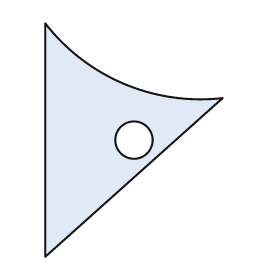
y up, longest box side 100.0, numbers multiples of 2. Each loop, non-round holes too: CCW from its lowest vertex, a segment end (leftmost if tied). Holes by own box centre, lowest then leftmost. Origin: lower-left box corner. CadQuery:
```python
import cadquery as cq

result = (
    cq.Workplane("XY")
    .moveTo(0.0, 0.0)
    .lineTo(76.0, 68.0)
    .threePointArc((34.0, 74.0), (0.0, 100.0))
    .close()
    .moveTo(38.0, 50.0)
    .circle(8.0)
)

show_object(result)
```